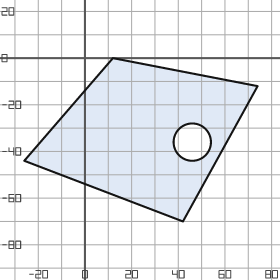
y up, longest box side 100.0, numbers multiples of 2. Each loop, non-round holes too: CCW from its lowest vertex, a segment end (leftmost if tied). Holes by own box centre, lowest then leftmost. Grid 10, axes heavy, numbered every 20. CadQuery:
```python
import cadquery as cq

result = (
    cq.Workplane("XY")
    .moveTo(42.0, -70.0)
    .lineTo(74.0, -12.0)
    .lineTo(12.0, 0.0)
    .lineTo(-26.0, -44.0)
    .close()
    .moveTo(46.0, -36.0)
    .circle(8.0)
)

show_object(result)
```